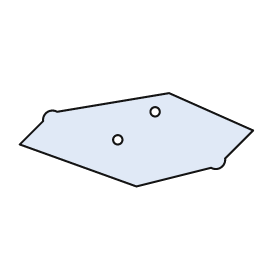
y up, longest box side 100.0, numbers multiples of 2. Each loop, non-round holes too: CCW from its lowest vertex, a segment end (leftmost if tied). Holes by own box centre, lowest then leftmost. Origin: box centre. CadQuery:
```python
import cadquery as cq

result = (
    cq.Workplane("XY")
    .moveTo(0.0, -20.0)
    .lineTo(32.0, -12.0)
    .threePointArc((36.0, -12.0), (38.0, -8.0))
    .lineTo(50.0, 4.0)
    .lineTo(14.0, 20.0)
    .lineTo(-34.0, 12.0)
    .threePointArc((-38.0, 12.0), (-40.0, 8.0))
    .lineTo(-50.0, -2.0)
    .close()
    .moveTo(-8.0, 0.0)
    .circle(2.0)
    .moveTo(8.0, 12.0)
    .circle(2.0)
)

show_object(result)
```